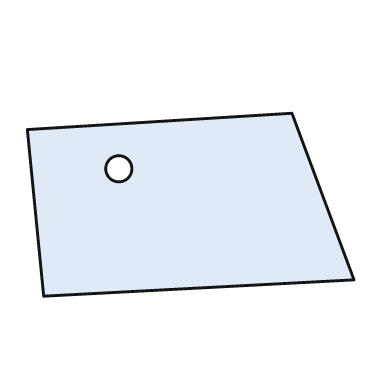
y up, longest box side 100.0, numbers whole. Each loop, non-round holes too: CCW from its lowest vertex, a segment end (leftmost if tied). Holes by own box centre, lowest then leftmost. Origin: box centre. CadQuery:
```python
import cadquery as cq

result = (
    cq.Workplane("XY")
    .moveTo(-45.0, -28.0)
    .lineTo(50.0, -23.0)
    .lineTo(31.0, 28.0)
    .lineTo(-50.0, 23.0)
    .close()
    .moveTo(-22.0, 11.0)
    .circle(4.0)
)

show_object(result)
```